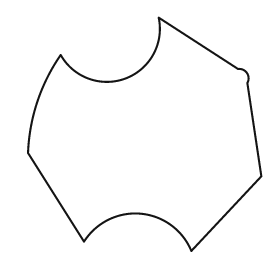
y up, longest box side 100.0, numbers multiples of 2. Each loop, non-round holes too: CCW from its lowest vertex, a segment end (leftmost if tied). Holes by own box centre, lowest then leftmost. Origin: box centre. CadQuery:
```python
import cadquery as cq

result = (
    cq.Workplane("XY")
    .moveTo(20.0, -50.0)
    .lineTo(50.0, -18.0)
    .lineTo(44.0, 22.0)
    .threePointArc((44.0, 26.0), (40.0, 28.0))
    .lineTo(6.0, 50.0)
    .threePointArc((-8.0, 24.0), (-36.0, 34.0))
    .threePointArc((-46.0, 14.0), (-50.0, -8.0))
    .lineTo(-26.0, -46.0)
    .threePointArc((-2.0, -34.0), (20.0, -50.0))
    .close()
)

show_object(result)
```